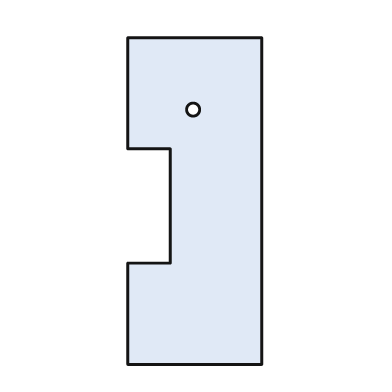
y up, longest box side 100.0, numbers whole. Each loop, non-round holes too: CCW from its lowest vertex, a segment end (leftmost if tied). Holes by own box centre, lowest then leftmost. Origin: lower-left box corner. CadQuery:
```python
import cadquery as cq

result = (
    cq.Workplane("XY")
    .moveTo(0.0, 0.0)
    .lineTo(41.0, 0.0)
    .lineTo(41.0, 100.0)
    .lineTo(0.0, 100.0)
    .lineTo(0.0, 66.0)
    .lineTo(13.0, 66.0)
    .lineTo(13.0, 31.0)
    .lineTo(0.0, 31.0)
    .close()
    .moveTo(20.0, 78.0)
    .circle(2.0)
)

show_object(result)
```